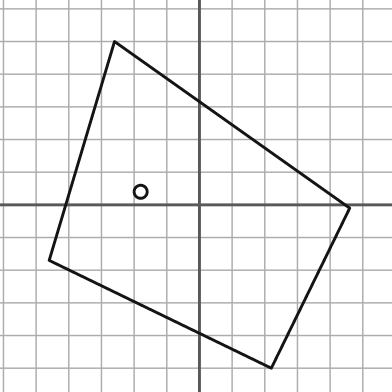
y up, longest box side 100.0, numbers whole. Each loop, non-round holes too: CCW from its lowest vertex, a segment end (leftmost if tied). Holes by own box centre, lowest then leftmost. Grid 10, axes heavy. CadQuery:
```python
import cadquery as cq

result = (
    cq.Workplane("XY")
    .moveTo(22.0, -50.0)
    .lineTo(46.0, -1.0)
    .lineTo(-26.0, 50.0)
    .lineTo(-46.0, -17.0)
    .close()
    .moveTo(-18.0, 4.0)
    .circle(2.0)
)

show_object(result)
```